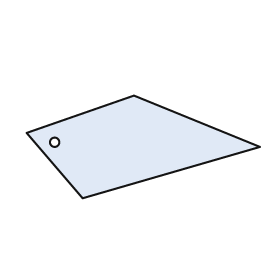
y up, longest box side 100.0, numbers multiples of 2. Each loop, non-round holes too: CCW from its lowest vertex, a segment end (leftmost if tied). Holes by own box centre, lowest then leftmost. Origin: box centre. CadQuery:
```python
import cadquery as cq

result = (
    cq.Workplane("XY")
    .moveTo(-26.0, -22.0)
    .lineTo(50.0, 0.0)
    .lineTo(-4.0, 22.0)
    .lineTo(-50.0, 6.0)
    .close()
    .moveTo(-38.0, 2.0)
    .circle(2.0)
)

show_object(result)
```